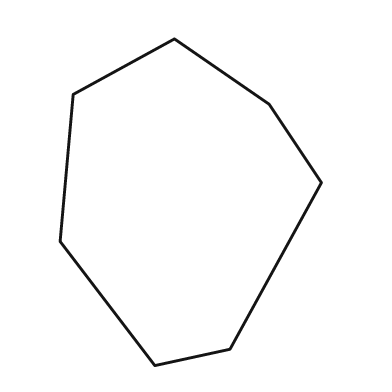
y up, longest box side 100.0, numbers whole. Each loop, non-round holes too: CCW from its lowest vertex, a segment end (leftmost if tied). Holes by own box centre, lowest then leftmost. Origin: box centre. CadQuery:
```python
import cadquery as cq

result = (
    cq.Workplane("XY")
    .moveTo(-11.0, -50.0)
    .lineTo(12.0, -45.0)
    .lineTo(40.0, 6.0)
    .lineTo(24.0, 30.0)
    .lineTo(-5.0, 50.0)
    .lineTo(-36.0, 33.0)
    .lineTo(-40.0, -12.0)
    .close()
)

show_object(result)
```